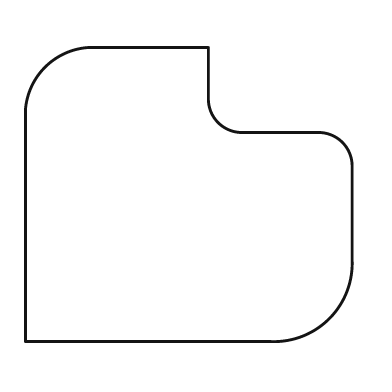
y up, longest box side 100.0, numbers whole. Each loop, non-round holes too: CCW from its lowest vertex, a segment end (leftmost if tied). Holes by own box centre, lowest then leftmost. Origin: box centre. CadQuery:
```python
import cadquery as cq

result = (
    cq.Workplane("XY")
    .moveTo(-50.0, -45.0)
    .lineTo(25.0, -45.0)
    .threePointArc((43.0, -38.0), (50.0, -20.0))
    .lineTo(50.0, 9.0)
    .threePointArc((47.0, 16.0), (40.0, 19.0))
    .lineTo(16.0, 19.0)
    .threePointArc((9.0, 22.0), (6.0, 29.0))
    .lineTo(6.0, 45.0)
    .lineTo(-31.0, 45.0)
    .threePointArc((-44.0, 39.0), (-50.0, 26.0))
    .close()
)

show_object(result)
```